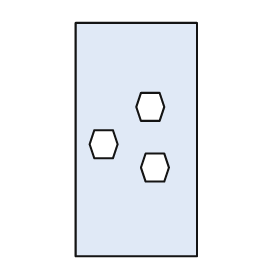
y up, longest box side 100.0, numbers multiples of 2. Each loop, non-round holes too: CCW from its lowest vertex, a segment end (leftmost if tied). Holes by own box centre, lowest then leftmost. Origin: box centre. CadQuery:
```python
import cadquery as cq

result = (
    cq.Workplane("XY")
    .moveTo(-26.0, -50.0)
    .lineTo(26.0, -50.0)
    .lineTo(26.0, 50.0)
    .lineTo(-26.0, 50.0)
    .close()
    .moveTo(4.0, -18.0)
    .lineTo(12.0, -18.0)
    .lineTo(14.0, -12.0)
    .lineTo(12.0, -6.0)
    .lineTo(4.0, -6.0)
    .lineTo(2.0, -12.0)
    .close()
    .moveTo(-18.0, -8.0)
    .lineTo(-10.0, -8.0)
    .lineTo(-8.0, -2.0)
    .lineTo(-10.0, 4.0)
    .lineTo(-18.0, 4.0)
    .lineTo(-20.0, -2.0)
    .close()
    .moveTo(2.0, 8.0)
    .lineTo(10.0, 8.0)
    .lineTo(12.0, 14.0)
    .lineTo(10.0, 20.0)
    .lineTo(2.0, 20.0)
    .lineTo(0.0, 14.0)
    .close()
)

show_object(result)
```